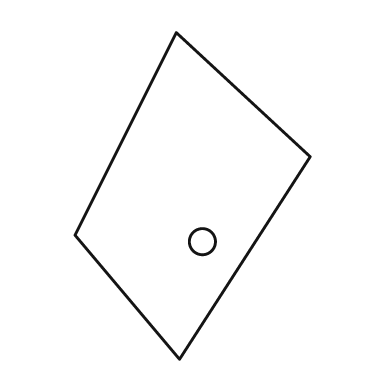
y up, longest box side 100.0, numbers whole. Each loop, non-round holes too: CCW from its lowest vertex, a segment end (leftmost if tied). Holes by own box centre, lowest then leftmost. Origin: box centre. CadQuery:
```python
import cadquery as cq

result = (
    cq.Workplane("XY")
    .moveTo(-4.0, -50.0)
    .lineTo(36.0, 12.0)
    .lineTo(-5.0, 50.0)
    .lineTo(-36.0, -12.0)
    .close()
    .moveTo(3.0, -14.0)
    .circle(4.0)
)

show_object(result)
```